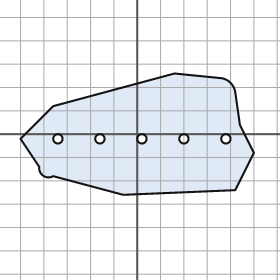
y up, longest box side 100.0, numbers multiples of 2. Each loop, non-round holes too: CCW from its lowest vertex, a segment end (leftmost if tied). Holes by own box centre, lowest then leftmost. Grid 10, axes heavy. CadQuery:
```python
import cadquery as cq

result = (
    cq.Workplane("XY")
    .moveTo(-6.0, -26.0)
    .lineTo(42.0, -24.0)
    .lineTo(50.0, -8.0)
    .lineTo(44.0, 4.0)
    .lineTo(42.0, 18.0)
    .threePointArc((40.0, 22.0), (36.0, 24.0))
    .lineTo(16.0, 26.0)
    .lineTo(-36.0, 12.0)
    .lineTo(-50.0, -2.0)
    .lineTo(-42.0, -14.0)
    .threePointArc((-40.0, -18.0), (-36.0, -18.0))
    .close()
    .moveTo(-34.0, -2.0)
    .circle(2.0)
    .moveTo(-16.0, -2.0)
    .circle(2.0)
    .moveTo(2.0, -2.0)
    .circle(2.0)
    .moveTo(20.0, -2.0)
    .circle(2.0)
    .moveTo(38.0, -2.0)
    .circle(2.0)
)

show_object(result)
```